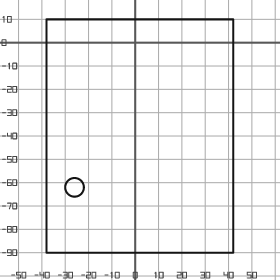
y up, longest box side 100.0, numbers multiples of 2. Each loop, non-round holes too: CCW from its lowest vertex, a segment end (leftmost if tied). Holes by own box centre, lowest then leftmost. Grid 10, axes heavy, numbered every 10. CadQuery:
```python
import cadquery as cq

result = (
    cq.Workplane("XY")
    .moveTo(-38.0, -90.0)
    .lineTo(42.0, -90.0)
    .lineTo(42.0, 10.0)
    .lineTo(-38.0, 10.0)
    .close()
    .moveTo(-26.0, -62.0)
    .circle(4.0)
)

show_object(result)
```